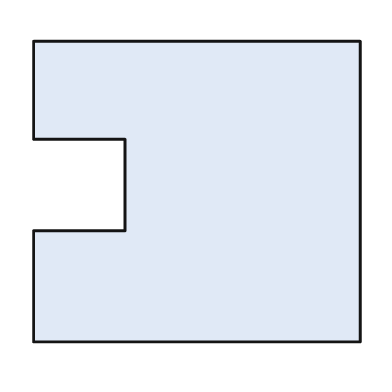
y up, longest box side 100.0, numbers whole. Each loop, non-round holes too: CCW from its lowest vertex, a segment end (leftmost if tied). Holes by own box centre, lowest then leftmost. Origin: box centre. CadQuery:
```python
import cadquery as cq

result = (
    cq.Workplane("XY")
    .moveTo(-50.0, -46.0)
    .lineTo(50.0, -46.0)
    .lineTo(50.0, 46.0)
    .lineTo(-50.0, 46.0)
    .lineTo(-50.0, 16.0)
    .lineTo(-22.0, 16.0)
    .lineTo(-22.0, -12.0)
    .lineTo(-50.0, -12.0)
    .close()
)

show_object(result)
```